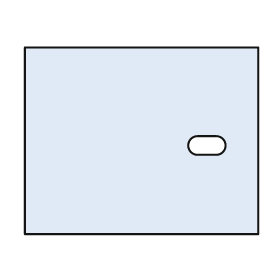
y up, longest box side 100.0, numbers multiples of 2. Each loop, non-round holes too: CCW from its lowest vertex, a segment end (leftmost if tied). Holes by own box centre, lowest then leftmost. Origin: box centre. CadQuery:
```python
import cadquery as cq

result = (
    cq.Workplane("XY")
    .moveTo(-50.0, -40.0)
    .lineTo(50.0, -40.0)
    .lineTo(50.0, 40.0)
    .lineTo(-50.0, 40.0)
    .close()
    .moveTo(24.0, -6.0)
    .lineTo(32.0, -6.0)
    .threePointArc((36.0, -2.0), (32.0, 2.0))
    .lineTo(24.0, 2.0)
    .threePointArc((20.0, -2.0), (24.0, -6.0))
    .close()
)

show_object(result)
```